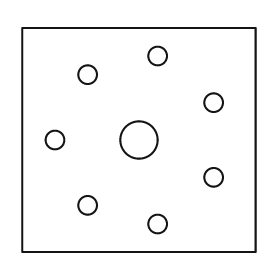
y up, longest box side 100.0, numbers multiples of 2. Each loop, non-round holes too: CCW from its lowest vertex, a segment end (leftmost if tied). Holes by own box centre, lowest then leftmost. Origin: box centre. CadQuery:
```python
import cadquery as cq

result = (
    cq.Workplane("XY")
    .moveTo(-50.0, -48.0)
    .lineTo(50.0, -48.0)
    .lineTo(50.0, 48.0)
    .lineTo(-50.0, 48.0)
    .close()
    .moveTo(8.0, -36.0)
    .circle(4.0)
    .moveTo(-22.0, -28.0)
    .circle(4.0)
    .moveTo(32.0, -16.0)
    .circle(4.0)
    .moveTo(-36.0, 0.0)
    .circle(4.0)
    .moveTo(0.0, 0.0)
    .circle(8.0)
    .moveTo(32.0, 16.0)
    .circle(4.0)
    .moveTo(-22.0, 28.0)
    .circle(4.0)
    .moveTo(8.0, 36.0)
    .circle(4.0)
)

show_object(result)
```